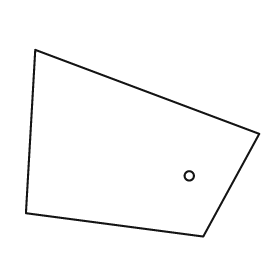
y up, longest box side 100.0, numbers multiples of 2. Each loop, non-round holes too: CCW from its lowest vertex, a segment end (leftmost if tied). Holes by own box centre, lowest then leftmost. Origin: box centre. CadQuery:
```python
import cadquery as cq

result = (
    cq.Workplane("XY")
    .moveTo(26.0, -40.0)
    .lineTo(50.0, 4.0)
    .lineTo(-46.0, 40.0)
    .lineTo(-50.0, -30.0)
    .close()
    .moveTo(20.0, -14.0)
    .circle(2.0)
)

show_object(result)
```